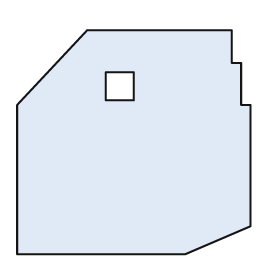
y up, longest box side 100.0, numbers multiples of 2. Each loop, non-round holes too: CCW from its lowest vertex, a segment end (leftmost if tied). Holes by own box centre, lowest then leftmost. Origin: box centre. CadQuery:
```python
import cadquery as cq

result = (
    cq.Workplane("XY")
    .moveTo(-50.0, -48.0)
    .lineTo(22.0, -48.0)
    .lineTo(50.0, -36.0)
    .lineTo(50.0, 16.0)
    .lineTo(46.0, 16.0)
    .lineTo(46.0, 34.0)
    .lineTo(42.0, 34.0)
    .lineTo(42.0, 48.0)
    .lineTo(-20.0, 48.0)
    .lineTo(-50.0, 16.0)
    .close()
    .moveTo(-12.0, 18.0)
    .lineTo(0.0, 18.0)
    .lineTo(0.0, 30.0)
    .lineTo(-12.0, 30.0)
    .close()
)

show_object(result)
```